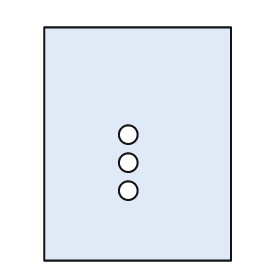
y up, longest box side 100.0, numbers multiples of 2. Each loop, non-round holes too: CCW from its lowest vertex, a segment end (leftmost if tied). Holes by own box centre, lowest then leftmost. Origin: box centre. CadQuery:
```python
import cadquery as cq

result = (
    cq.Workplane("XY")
    .moveTo(-40.0, -50.0)
    .lineTo(40.0, -50.0)
    .lineTo(40.0, 50.0)
    .lineTo(-40.0, 50.0)
    .close()
    .moveTo(-4.0, -20.0)
    .circle(4.0)
    .moveTo(-4.0, -8.0)
    .circle(4.0)
    .moveTo(-4.0, 4.0)
    .circle(4.0)
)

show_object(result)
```